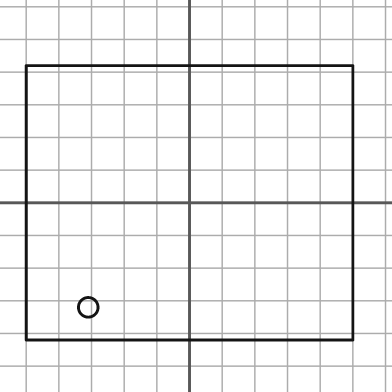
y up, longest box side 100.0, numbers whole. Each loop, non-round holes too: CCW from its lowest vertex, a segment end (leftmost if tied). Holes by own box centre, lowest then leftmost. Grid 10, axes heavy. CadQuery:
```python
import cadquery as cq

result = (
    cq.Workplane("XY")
    .moveTo(-50.0, -42.0)
    .lineTo(50.0, -42.0)
    .lineTo(50.0, 42.0)
    .lineTo(-50.0, 42.0)
    .close()
    .moveTo(-31.0, -32.0)
    .circle(3.0)
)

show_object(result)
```